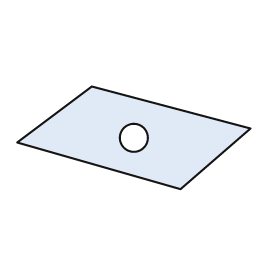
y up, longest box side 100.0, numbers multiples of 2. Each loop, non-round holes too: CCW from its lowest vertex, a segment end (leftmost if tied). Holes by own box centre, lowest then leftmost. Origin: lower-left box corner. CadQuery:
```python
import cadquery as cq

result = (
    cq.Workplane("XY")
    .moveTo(70.0, 0.0)
    .lineTo(100.0, 26.0)
    .lineTo(32.0, 44.0)
    .lineTo(0.0, 20.0)
    .close()
    .moveTo(50.0, 22.0)
    .circle(6.0)
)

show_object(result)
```